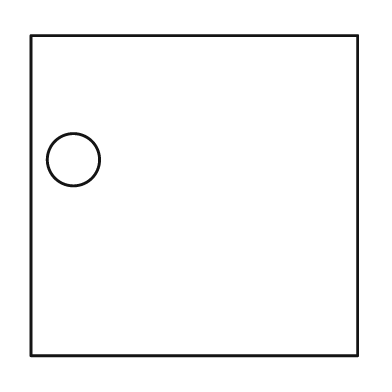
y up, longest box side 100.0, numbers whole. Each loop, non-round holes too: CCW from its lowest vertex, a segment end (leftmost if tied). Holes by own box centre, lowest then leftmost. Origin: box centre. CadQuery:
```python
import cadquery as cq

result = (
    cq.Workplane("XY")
    .moveTo(-50.0, -49.0)
    .lineTo(50.0, -49.0)
    .lineTo(50.0, 49.0)
    .lineTo(-50.0, 49.0)
    .close()
    .moveTo(-37.0, 11.0)
    .circle(8.0)
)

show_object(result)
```